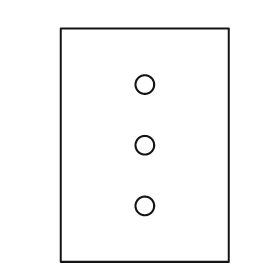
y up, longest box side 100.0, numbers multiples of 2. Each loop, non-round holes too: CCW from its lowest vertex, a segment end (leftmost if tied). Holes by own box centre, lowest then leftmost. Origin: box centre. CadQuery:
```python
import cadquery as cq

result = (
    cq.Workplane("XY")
    .moveTo(-36.0, -50.0)
    .lineTo(36.0, -50.0)
    .lineTo(36.0, 50.0)
    .lineTo(-36.0, 50.0)
    .close()
    .moveTo(0.0, -26.0)
    .circle(4.0)
    .moveTo(0.0, 0.0)
    .circle(4.0)
    .moveTo(0.0, 26.0)
    .circle(4.0)
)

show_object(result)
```